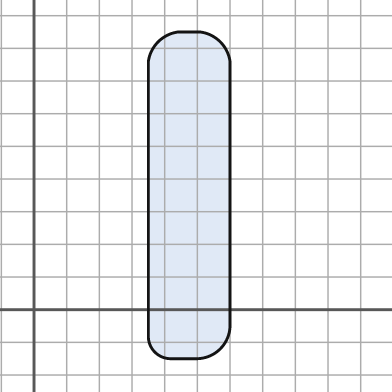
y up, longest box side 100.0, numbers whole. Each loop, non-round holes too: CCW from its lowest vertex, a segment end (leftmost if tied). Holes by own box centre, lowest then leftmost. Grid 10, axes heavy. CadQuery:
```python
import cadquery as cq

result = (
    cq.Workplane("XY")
    .moveTo(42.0, -15.0)
    .lineTo(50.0, -15.0)
    .threePointArc((57.0, -12.0), (60.0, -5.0))
    .lineTo(60.0, 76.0)
    .threePointArc((57.0, 82.0), (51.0, 85.0))
    .lineTo(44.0, 85.0)
    .threePointArc((38.0, 82.0), (35.0, 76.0))
    .lineTo(35.0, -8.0)
    .threePointArc((37.0, -13.0), (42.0, -15.0))
    .close()
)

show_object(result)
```